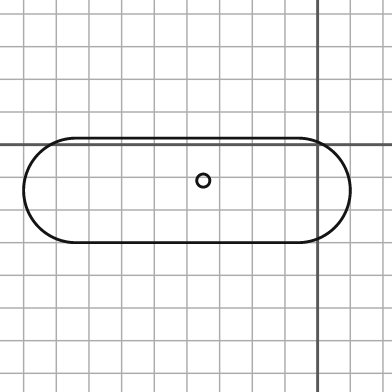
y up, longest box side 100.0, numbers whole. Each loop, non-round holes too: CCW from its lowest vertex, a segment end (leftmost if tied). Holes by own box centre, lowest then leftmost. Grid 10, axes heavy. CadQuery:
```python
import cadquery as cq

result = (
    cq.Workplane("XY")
    .moveTo(-74.0, -30.0)
    .lineTo(-6.0, -30.0)
    .threePointArc((10.0, -14.0), (-6.0, 2.0))
    .lineTo(-74.0, 2.0)
    .threePointArc((-90.0, -14.0), (-74.0, -30.0))
    .close()
    .moveTo(-35.0, -11.0)
    .circle(2.0)
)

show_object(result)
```